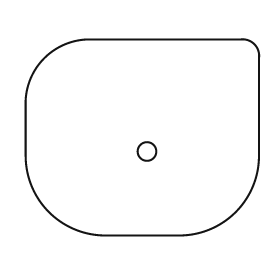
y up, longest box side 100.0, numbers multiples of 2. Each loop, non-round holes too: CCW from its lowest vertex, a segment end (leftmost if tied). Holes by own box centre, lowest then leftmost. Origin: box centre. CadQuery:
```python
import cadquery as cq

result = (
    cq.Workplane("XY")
    .moveTo(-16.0, -42.0)
    .lineTo(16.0, -42.0)
    .threePointArc((40.0, -32.0), (50.0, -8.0))
    .lineTo(50.0, 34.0)
    .threePointArc((48.0, 40.0), (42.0, 42.0))
    .lineTo(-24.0, 42.0)
    .threePointArc((-42.0, 34.0), (-50.0, 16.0))
    .lineTo(-50.0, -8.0)
    .threePointArc((-40.0, -32.0), (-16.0, -42.0))
    .close()
    .moveTo(2.0, -6.0)
    .circle(4.0)
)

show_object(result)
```